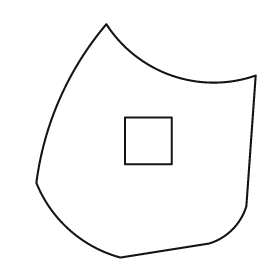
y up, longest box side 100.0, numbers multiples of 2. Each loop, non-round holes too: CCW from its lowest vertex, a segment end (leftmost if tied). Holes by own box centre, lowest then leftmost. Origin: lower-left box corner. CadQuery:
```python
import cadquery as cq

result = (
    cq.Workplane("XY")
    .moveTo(36.0, 0.0)
    .lineTo(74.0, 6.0)
    .threePointArc((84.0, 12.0), (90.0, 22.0))
    .lineTo(94.0, 78.0)
    .threePointArc((58.0, 78.0), (30.0, 100.0))
    .threePointArc((10.0, 68.0), (0.0, 32.0))
    .threePointArc((14.0, 12.0), (36.0, 0.0))
    .close()
    .moveTo(38.0, 40.0)
    .lineTo(58.0, 40.0)
    .lineTo(58.0, 60.0)
    .lineTo(38.0, 60.0)
    .close()
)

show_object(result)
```